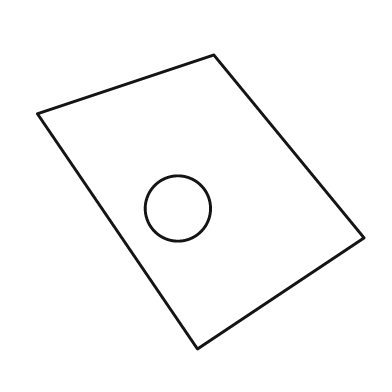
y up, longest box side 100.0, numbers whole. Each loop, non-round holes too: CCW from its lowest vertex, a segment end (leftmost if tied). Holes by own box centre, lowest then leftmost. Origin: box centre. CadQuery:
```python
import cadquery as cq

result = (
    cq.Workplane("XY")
    .moveTo(-1.0, -45.0)
    .lineTo(50.0, -11.0)
    .lineTo(4.0, 45.0)
    .lineTo(-50.0, 27.0)
    .close()
    .moveTo(-7.0, -2.0)
    .circle(10.0)
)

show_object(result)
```